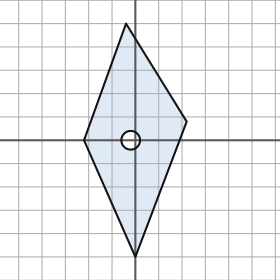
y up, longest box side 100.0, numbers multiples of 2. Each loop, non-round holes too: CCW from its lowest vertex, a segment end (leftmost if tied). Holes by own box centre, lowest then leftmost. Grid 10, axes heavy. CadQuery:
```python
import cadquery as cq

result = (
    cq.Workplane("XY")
    .moveTo(0.0, -50.0)
    .lineTo(22.0, 8.0)
    .lineTo(-4.0, 50.0)
    .lineTo(-22.0, 0.0)
    .close()
    .moveTo(-2.0, 0.0)
    .circle(4.0)
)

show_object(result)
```